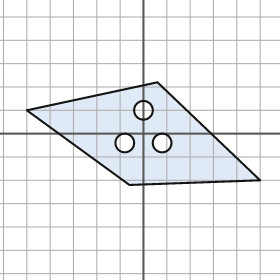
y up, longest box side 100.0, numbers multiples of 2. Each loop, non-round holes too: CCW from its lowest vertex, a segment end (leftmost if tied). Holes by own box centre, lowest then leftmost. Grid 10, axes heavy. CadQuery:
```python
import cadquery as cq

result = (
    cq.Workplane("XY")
    .moveTo(-6.0, -22.0)
    .lineTo(50.0, -20.0)
    .lineTo(6.0, 22.0)
    .lineTo(-50.0, 10.0)
    .close()
    .moveTo(-8.0, -4.0)
    .circle(4.0)
    .moveTo(8.0, -4.0)
    .circle(4.0)
    .moveTo(0.0, 10.0)
    .circle(4.0)
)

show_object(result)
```